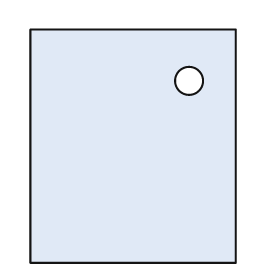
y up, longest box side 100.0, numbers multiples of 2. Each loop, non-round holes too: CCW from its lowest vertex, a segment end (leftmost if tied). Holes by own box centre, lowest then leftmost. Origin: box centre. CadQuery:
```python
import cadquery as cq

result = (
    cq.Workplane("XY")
    .moveTo(-44.0, -50.0)
    .lineTo(44.0, -50.0)
    .lineTo(44.0, 50.0)
    .lineTo(-44.0, 50.0)
    .close()
    .moveTo(24.0, 28.0)
    .circle(6.0)
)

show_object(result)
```